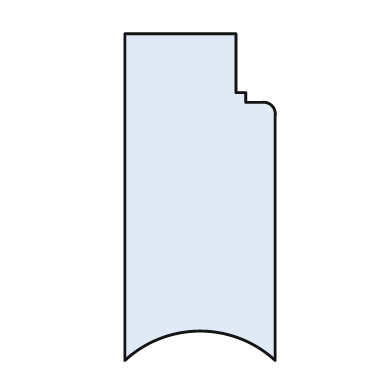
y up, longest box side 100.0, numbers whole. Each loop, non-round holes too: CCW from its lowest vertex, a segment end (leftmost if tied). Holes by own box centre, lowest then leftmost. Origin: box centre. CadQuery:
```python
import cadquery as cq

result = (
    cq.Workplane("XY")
    .moveTo(-23.0, -50.0)
    .threePointArc((0.0, -41.0), (23.0, -50.0))
    .lineTo(23.0, 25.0)
    .threePointArc((22.0, 28.0), (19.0, 29.0))
    .lineTo(14.0, 29.0)
    .lineTo(14.0, 32.0)
    .lineTo(11.0, 32.0)
    .lineTo(11.0, 50.0)
    .lineTo(-23.0, 50.0)
    .close()
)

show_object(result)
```